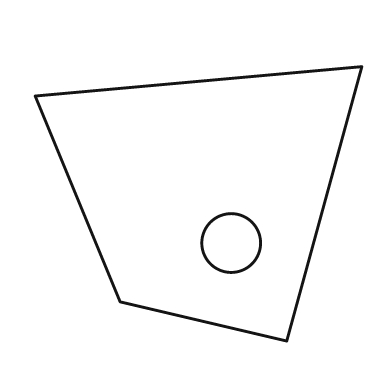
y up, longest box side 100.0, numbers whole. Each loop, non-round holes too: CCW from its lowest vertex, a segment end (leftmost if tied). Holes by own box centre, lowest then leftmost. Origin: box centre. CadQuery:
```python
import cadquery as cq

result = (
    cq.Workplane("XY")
    .moveTo(27.0, -42.0)
    .lineTo(50.0, 42.0)
    .lineTo(-50.0, 33.0)
    .lineTo(-24.0, -30.0)
    .close()
    .moveTo(10.0, -12.0)
    .circle(9.0)
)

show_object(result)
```